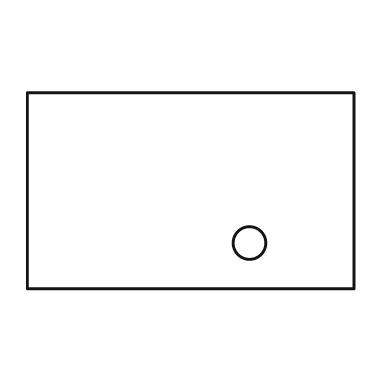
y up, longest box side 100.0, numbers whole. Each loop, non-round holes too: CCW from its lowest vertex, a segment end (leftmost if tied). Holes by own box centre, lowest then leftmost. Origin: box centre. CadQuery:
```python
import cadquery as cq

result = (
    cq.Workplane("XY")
    .moveTo(-50.0, -30.0)
    .lineTo(50.0, -30.0)
    .lineTo(50.0, 30.0)
    .lineTo(-50.0, 30.0)
    .close()
    .moveTo(18.0, -16.0)
    .circle(5.0)
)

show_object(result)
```